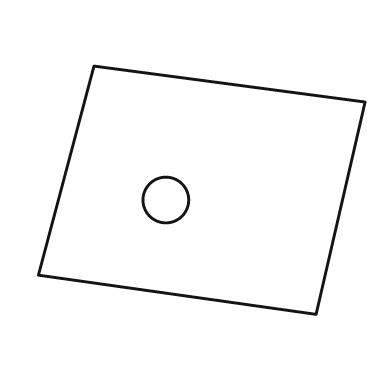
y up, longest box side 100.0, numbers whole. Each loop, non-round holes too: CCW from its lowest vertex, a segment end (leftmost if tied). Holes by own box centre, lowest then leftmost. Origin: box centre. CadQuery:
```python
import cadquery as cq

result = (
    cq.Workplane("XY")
    .moveTo(35.0, -38.0)
    .lineTo(50.0, 27.0)
    .lineTo(-33.0, 38.0)
    .lineTo(-50.0, -26.0)
    .close()
    .moveTo(-11.0, -3.0)
    .circle(7.0)
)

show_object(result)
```